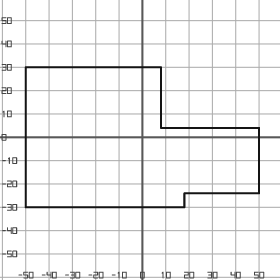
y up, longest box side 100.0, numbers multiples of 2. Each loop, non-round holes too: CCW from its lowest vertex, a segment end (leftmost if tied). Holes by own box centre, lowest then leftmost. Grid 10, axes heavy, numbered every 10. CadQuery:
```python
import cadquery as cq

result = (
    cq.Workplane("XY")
    .moveTo(-50.0, -30.0)
    .lineTo(18.0, -30.0)
    .lineTo(18.0, -24.0)
    .lineTo(50.0, -24.0)
    .lineTo(50.0, 4.0)
    .lineTo(8.0, 4.0)
    .lineTo(8.0, 30.0)
    .lineTo(-50.0, 30.0)
    .close()
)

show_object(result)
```